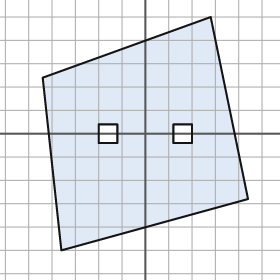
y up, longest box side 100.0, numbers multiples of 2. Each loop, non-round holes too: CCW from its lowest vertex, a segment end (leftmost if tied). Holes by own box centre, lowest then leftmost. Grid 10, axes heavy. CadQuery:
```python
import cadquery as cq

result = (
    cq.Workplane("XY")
    .moveTo(-36.0, -50.0)
    .lineTo(44.0, -28.0)
    .lineTo(28.0, 50.0)
    .lineTo(-44.0, 24.0)
    .close()
    .moveTo(-20.0, -4.0)
    .lineTo(-12.0, -4.0)
    .lineTo(-12.0, 4.0)
    .lineTo(-20.0, 4.0)
    .close()
    .moveTo(12.0, -4.0)
    .lineTo(20.0, -4.0)
    .lineTo(20.0, 4.0)
    .lineTo(12.0, 4.0)
    .close()
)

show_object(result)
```